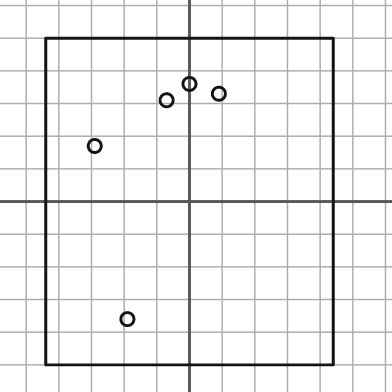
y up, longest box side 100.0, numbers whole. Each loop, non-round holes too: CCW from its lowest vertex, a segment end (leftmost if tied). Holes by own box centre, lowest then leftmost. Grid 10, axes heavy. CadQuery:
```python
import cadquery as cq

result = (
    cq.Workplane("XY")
    .moveTo(-44.0, -50.0)
    .lineTo(44.0, -50.0)
    .lineTo(44.0, 50.0)
    .lineTo(-44.0, 50.0)
    .close()
    .moveTo(-19.0, -36.0)
    .circle(2.0)
    .moveTo(-29.0, 17.0)
    .circle(2.0)
    .moveTo(-7.0, 31.0)
    .circle(2.0)
    .moveTo(9.0, 33.0)
    .circle(2.0)
    .moveTo(0.0, 36.0)
    .circle(2.0)
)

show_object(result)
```